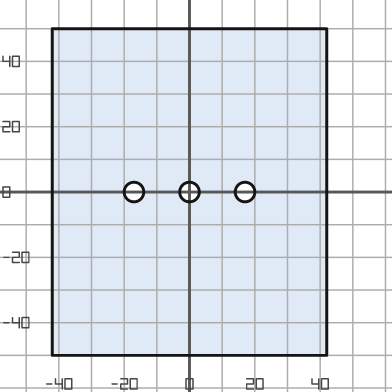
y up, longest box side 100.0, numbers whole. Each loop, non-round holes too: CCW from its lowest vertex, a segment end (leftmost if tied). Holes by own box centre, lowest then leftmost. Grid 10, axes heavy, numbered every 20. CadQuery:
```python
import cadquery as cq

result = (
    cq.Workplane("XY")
    .moveTo(-42.0, -50.0)
    .lineTo(42.0, -50.0)
    .lineTo(42.0, 50.0)
    .lineTo(-42.0, 50.0)
    .close()
    .moveTo(-17.0, 0.0)
    .circle(3.0)
    .moveTo(0.0, 0.0)
    .circle(3.0)
    .moveTo(17.0, 0.0)
    .circle(3.0)
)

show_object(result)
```